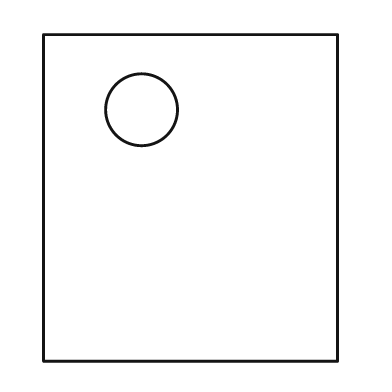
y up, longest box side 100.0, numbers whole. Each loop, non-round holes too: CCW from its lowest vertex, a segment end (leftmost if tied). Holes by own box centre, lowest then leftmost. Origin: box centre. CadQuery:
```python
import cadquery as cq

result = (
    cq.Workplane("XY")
    .moveTo(-45.0, -50.0)
    .lineTo(45.0, -50.0)
    .lineTo(45.0, 50.0)
    .lineTo(-45.0, 50.0)
    .close()
    .moveTo(-15.0, 27.0)
    .circle(11.0)
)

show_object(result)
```